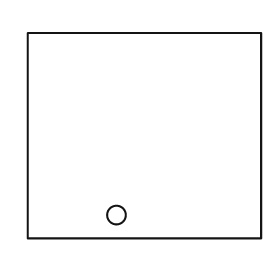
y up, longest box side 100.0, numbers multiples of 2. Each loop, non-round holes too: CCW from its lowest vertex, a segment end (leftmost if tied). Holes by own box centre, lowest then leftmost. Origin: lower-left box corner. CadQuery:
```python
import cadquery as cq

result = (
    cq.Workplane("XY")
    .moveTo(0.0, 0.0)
    .lineTo(100.0, 0.0)
    .lineTo(100.0, 88.0)
    .lineTo(0.0, 88.0)
    .close()
    .moveTo(38.0, 10.0)
    .circle(4.0)
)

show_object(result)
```